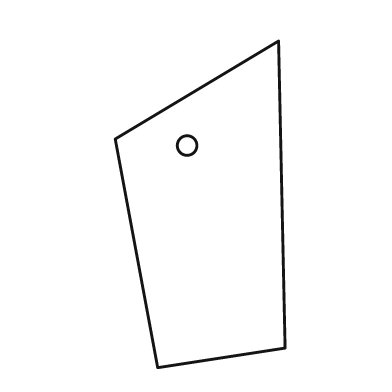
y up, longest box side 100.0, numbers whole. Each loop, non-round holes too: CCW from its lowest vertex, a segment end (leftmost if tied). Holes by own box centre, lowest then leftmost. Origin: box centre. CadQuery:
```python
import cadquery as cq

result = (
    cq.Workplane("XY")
    .moveTo(-13.0, -50.0)
    .lineTo(26.0, -44.0)
    .lineTo(24.0, 50.0)
    .lineTo(-26.0, 20.0)
    .close()
    .moveTo(-4.0, 18.0)
    .circle(3.0)
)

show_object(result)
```